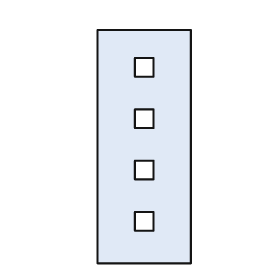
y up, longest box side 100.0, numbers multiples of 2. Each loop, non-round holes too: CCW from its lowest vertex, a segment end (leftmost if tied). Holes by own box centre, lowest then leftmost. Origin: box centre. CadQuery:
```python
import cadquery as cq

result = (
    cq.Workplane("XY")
    .moveTo(-20.0, -50.0)
    .lineTo(20.0, -50.0)
    .lineTo(20.0, 50.0)
    .lineTo(-20.0, 50.0)
    .close()
    .moveTo(-4.0, -36.0)
    .lineTo(4.0, -36.0)
    .lineTo(4.0, -28.0)
    .lineTo(-4.0, -28.0)
    .close()
    .moveTo(-4.0, -14.0)
    .lineTo(4.0, -14.0)
    .lineTo(4.0, -6.0)
    .lineTo(-4.0, -6.0)
    .close()
    .moveTo(-4.0, 8.0)
    .lineTo(4.0, 8.0)
    .lineTo(4.0, 16.0)
    .lineTo(-4.0, 16.0)
    .close()
    .moveTo(-4.0, 30.0)
    .lineTo(4.0, 30.0)
    .lineTo(4.0, 38.0)
    .lineTo(-4.0, 38.0)
    .close()
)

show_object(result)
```